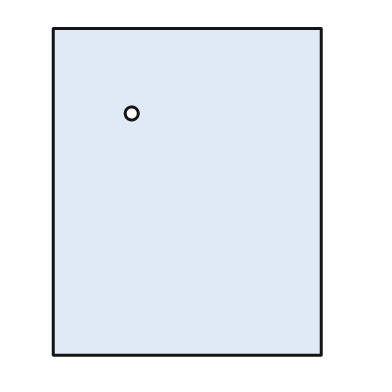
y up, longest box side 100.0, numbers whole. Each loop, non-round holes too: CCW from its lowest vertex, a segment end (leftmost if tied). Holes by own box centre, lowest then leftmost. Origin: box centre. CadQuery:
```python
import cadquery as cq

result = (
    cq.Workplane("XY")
    .moveTo(-41.0, -50.0)
    .lineTo(41.0, -50.0)
    .lineTo(41.0, 50.0)
    .lineTo(-41.0, 50.0)
    .close()
    .moveTo(-17.0, 24.0)
    .circle(2.0)
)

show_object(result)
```